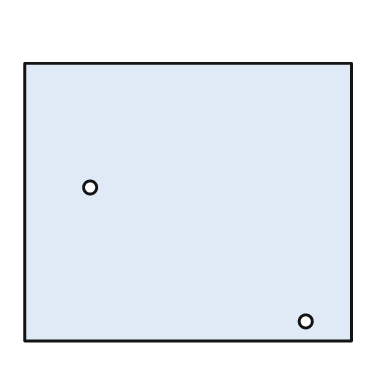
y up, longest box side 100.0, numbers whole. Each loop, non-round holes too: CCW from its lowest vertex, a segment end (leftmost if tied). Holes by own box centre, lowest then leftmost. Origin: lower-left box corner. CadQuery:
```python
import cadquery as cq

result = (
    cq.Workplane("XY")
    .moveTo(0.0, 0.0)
    .lineTo(100.0, 0.0)
    .lineTo(100.0, 85.0)
    .lineTo(0.0, 85.0)
    .close()
    .moveTo(86.0, 6.0)
    .circle(2.0)
    .moveTo(20.0, 47.0)
    .circle(2.0)
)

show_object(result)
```